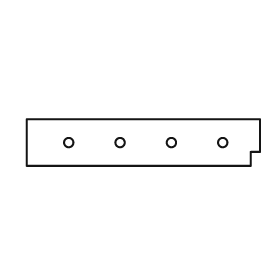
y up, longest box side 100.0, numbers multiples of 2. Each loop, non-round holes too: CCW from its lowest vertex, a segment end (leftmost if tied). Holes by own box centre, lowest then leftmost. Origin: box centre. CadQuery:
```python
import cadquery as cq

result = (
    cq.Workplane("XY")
    .moveTo(-50.0, -10.0)
    .lineTo(46.0, -10.0)
    .lineTo(46.0, -4.0)
    .lineTo(50.0, -4.0)
    .lineTo(50.0, 10.0)
    .lineTo(-50.0, 10.0)
    .close()
    .moveTo(-32.0, 0.0)
    .circle(2.0)
    .moveTo(-10.0, 0.0)
    .circle(2.0)
    .moveTo(12.0, 0.0)
    .circle(2.0)
    .moveTo(34.0, 0.0)
    .circle(2.0)
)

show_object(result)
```